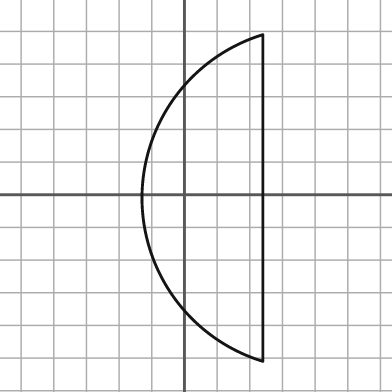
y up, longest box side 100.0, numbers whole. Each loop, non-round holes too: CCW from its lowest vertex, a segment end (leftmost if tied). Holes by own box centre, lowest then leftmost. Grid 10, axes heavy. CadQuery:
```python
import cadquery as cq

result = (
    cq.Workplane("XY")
    .moveTo(24.0, -51.0)
    .lineTo(24.0, 49.0)
    .threePointArc((-13.0, -1.0), (24.0, -51.0))
    .close()
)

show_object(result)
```